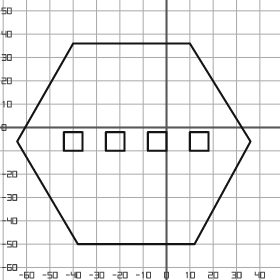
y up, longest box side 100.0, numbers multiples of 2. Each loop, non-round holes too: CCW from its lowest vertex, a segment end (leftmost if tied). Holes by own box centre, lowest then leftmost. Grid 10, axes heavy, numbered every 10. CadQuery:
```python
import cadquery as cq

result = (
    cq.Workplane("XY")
    .moveTo(-38.0, -50.0)
    .lineTo(12.0, -50.0)
    .lineTo(36.0, -6.0)
    .lineTo(10.0, 36.0)
    .lineTo(-40.0, 36.0)
    .lineTo(-64.0, -6.0)
    .close()
    .moveTo(-44.0, -10.0)
    .lineTo(-36.0, -10.0)
    .lineTo(-36.0, -2.0)
    .lineTo(-44.0, -2.0)
    .close()
    .moveTo(-26.0, -10.0)
    .lineTo(-18.0, -10.0)
    .lineTo(-18.0, -2.0)
    .lineTo(-26.0, -2.0)
    .close()
    .moveTo(-8.0, -10.0)
    .lineTo(0.0, -10.0)
    .lineTo(0.0, -2.0)
    .lineTo(-8.0, -2.0)
    .close()
    .moveTo(10.0, -10.0)
    .lineTo(18.0, -10.0)
    .lineTo(18.0, -2.0)
    .lineTo(10.0, -2.0)
    .close()
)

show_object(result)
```